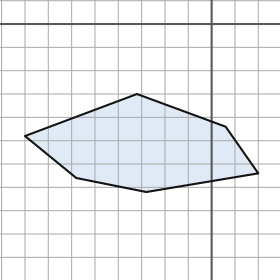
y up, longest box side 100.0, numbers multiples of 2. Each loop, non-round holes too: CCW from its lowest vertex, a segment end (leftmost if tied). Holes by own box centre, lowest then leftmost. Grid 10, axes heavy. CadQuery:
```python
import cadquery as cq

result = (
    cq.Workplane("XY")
    .moveTo(-28.0, -72.0)
    .lineTo(20.0, -64.0)
    .lineTo(6.0, -44.0)
    .lineTo(-32.0, -30.0)
    .lineTo(-80.0, -48.0)
    .lineTo(-58.0, -66.0)
    .close()
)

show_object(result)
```